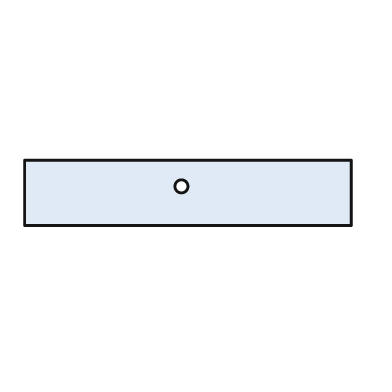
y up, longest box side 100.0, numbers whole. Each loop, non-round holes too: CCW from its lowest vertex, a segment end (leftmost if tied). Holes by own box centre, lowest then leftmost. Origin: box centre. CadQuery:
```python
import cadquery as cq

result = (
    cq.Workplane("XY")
    .moveTo(-50.0, -10.0)
    .lineTo(50.0, -10.0)
    .lineTo(50.0, 10.0)
    .lineTo(-50.0, 10.0)
    .close()
    .moveTo(-2.0, 2.0)
    .circle(2.0)
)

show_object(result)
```